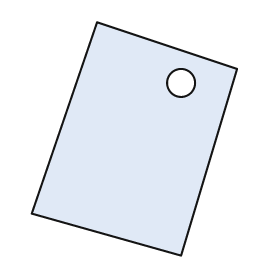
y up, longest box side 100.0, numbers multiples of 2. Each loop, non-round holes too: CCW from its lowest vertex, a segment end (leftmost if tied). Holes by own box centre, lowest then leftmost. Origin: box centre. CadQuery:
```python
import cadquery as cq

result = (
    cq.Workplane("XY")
    .moveTo(20.0, -50.0)
    .lineTo(44.0, 30.0)
    .lineTo(-16.0, 50.0)
    .lineTo(-44.0, -32.0)
    .close()
    .moveTo(20.0, 24.0)
    .circle(6.0)
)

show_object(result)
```